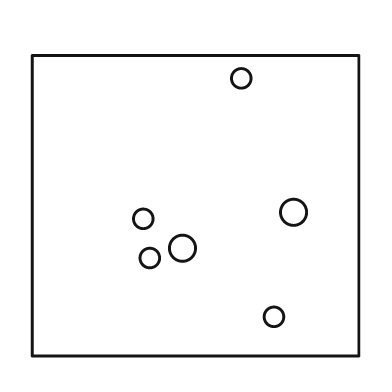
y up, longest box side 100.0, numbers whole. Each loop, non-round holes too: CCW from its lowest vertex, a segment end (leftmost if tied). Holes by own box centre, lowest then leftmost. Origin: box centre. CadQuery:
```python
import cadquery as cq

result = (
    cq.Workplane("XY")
    .moveTo(-50.0, -46.0)
    .lineTo(50.0, -46.0)
    .lineTo(50.0, 46.0)
    .lineTo(-50.0, 46.0)
    .close()
    .moveTo(24.0, -34.0)
    .circle(3.0)
    .moveTo(-14.0, -16.0)
    .circle(3.0)
    .moveTo(-4.0, -13.0)
    .circle(4.0)
    .moveTo(-16.0, -4.0)
    .circle(3.0)
    .moveTo(30.0, -2.0)
    .circle(4.0)
    .moveTo(14.0, 39.0)
    .circle(3.0)
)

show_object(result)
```